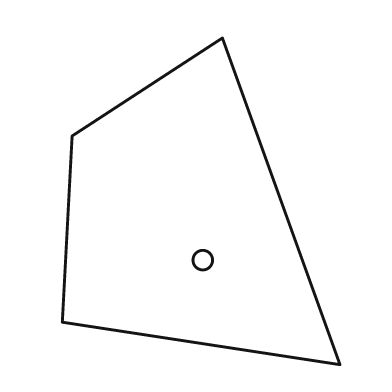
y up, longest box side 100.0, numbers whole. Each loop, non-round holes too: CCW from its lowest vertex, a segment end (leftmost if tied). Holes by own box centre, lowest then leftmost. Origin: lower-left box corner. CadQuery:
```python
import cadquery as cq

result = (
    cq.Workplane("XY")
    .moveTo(85.0, 0.0)
    .lineTo(49.0, 100.0)
    .lineTo(3.0, 70.0)
    .lineTo(0.0, 13.0)
    .close()
    .moveTo(43.0, 32.0)
    .circle(3.0)
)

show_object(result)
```